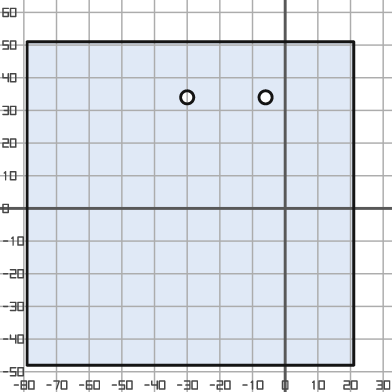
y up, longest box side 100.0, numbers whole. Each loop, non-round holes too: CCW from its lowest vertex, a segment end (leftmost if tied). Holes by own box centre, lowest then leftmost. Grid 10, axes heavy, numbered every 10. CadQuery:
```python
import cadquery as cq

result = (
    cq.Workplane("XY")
    .moveTo(-79.0, -48.0)
    .lineTo(21.0, -48.0)
    .lineTo(21.0, 51.0)
    .lineTo(-79.0, 51.0)
    .close()
    .moveTo(-30.0, 34.0)
    .circle(2.0)
    .moveTo(-6.0, 34.0)
    .circle(2.0)
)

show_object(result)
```